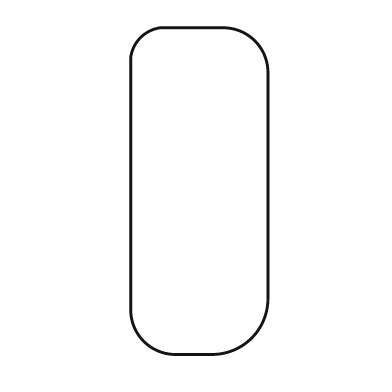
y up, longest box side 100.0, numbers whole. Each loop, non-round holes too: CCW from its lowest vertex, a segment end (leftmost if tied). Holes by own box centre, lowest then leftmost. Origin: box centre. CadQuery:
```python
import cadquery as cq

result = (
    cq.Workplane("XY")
    .moveTo(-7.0, -50.0)
    .lineTo(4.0, -50.0)
    .threePointArc((16.0, -45.0), (21.0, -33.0))
    .lineTo(21.0, 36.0)
    .threePointArc((17.0, 46.0), (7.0, 50.0))
    .lineTo(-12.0, 50.0)
    .threePointArc((-18.0, 47.0), (-21.0, 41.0))
    .lineTo(-21.0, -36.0)
    .threePointArc((-17.0, -46.0), (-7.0, -50.0))
    .close()
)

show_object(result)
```